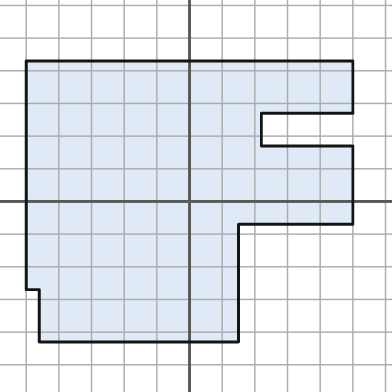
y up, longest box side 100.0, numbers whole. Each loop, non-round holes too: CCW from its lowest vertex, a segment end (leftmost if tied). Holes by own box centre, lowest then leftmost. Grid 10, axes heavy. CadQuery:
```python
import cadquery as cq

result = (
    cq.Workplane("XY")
    .moveTo(-46.0, -43.0)
    .lineTo(15.0, -43.0)
    .lineTo(15.0, -7.0)
    .lineTo(50.0, -7.0)
    .lineTo(50.0, 17.0)
    .lineTo(22.0, 17.0)
    .lineTo(22.0, 27.0)
    .lineTo(50.0, 27.0)
    .lineTo(50.0, 43.0)
    .lineTo(-50.0, 43.0)
    .lineTo(-50.0, -27.0)
    .lineTo(-46.0, -27.0)
    .close()
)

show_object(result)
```